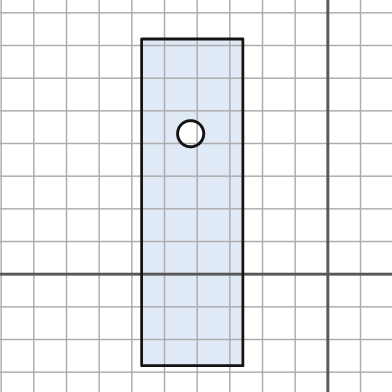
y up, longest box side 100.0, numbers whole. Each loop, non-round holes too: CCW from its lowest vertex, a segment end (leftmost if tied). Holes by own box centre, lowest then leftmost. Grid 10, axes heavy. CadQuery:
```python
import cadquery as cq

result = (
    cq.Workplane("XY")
    .moveTo(-57.0, -28.0)
    .lineTo(-26.0, -28.0)
    .lineTo(-26.0, 72.0)
    .lineTo(-57.0, 72.0)
    .close()
    .moveTo(-42.0, 43.0)
    .circle(4.0)
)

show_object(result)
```